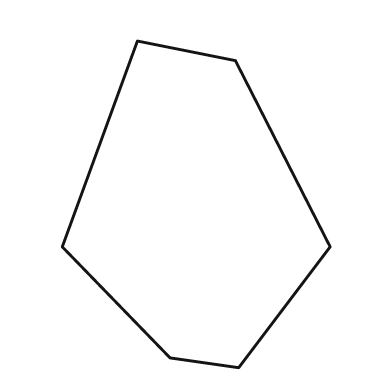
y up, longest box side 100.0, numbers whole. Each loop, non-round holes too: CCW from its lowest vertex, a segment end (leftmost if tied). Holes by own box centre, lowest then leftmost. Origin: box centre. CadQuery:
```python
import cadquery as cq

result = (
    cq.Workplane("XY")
    .moveTo(13.0, -50.0)
    .lineTo(41.0, -13.0)
    .lineTo(12.0, 44.0)
    .lineTo(-18.0, 50.0)
    .lineTo(-41.0, -13.0)
    .lineTo(-8.0, -47.0)
    .close()
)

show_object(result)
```